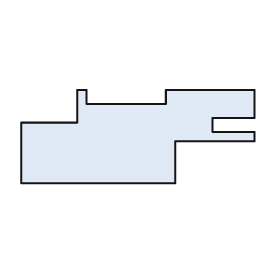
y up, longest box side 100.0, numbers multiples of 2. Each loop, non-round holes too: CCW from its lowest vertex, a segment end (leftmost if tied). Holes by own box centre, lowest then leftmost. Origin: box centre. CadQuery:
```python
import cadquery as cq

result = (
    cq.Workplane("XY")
    .moveTo(-50.0, -20.0)
    .lineTo(16.0, -20.0)
    .lineTo(16.0, -2.0)
    .lineTo(50.0, -2.0)
    .lineTo(50.0, 2.0)
    .lineTo(32.0, 2.0)
    .lineTo(32.0, 8.0)
    .lineTo(50.0, 8.0)
    .lineTo(50.0, 20.0)
    .lineTo(12.0, 20.0)
    .lineTo(12.0, 14.0)
    .lineTo(-22.0, 14.0)
    .lineTo(-22.0, 20.0)
    .lineTo(-26.0, 20.0)
    .lineTo(-26.0, 6.0)
    .lineTo(-50.0, 6.0)
    .close()
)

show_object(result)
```